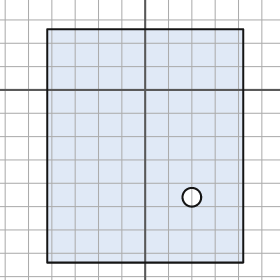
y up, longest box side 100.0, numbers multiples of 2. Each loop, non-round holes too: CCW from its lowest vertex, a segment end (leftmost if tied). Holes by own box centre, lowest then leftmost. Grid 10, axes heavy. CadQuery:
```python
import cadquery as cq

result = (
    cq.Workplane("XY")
    .moveTo(-42.0, -74.0)
    .lineTo(42.0, -74.0)
    .lineTo(42.0, 26.0)
    .lineTo(-42.0, 26.0)
    .close()
    .moveTo(20.0, -46.0)
    .circle(4.0)
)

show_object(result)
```